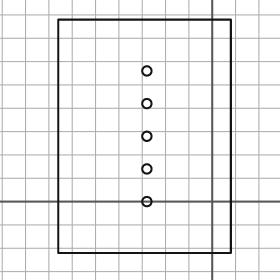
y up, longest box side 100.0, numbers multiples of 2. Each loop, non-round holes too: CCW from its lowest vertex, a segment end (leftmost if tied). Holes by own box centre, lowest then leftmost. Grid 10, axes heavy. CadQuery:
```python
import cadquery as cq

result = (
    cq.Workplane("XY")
    .moveTo(-66.0, -22.0)
    .lineTo(8.0, -22.0)
    .lineTo(8.0, 78.0)
    .lineTo(-66.0, 78.0)
    .close()
    .moveTo(-28.0, 0.0)
    .circle(2.0)
    .moveTo(-28.0, 14.0)
    .circle(2.0)
    .moveTo(-28.0, 28.0)
    .circle(2.0)
    .moveTo(-28.0, 42.0)
    .circle(2.0)
    .moveTo(-28.0, 56.0)
    .circle(2.0)
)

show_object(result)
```